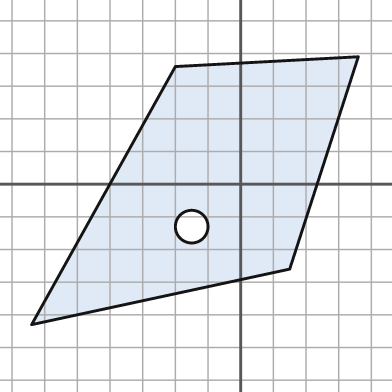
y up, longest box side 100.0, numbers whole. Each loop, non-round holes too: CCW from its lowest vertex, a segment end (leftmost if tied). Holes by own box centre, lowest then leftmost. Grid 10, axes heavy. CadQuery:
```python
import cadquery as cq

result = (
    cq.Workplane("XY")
    .moveTo(-64.0, -43.0)
    .lineTo(15.0, -26.0)
    .lineTo(36.0, 39.0)
    .lineTo(-20.0, 36.0)
    .close()
    .moveTo(-15.0, -13.0)
    .circle(5.0)
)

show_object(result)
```